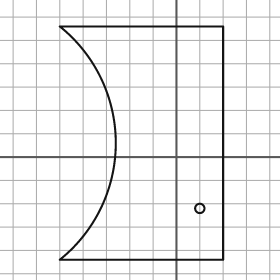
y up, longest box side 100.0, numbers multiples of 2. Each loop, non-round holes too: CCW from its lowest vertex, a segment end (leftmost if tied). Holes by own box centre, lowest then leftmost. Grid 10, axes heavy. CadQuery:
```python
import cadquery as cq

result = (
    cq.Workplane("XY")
    .moveTo(-50.0, -44.0)
    .lineTo(20.0, -44.0)
    .lineTo(20.0, 56.0)
    .lineTo(-50.0, 56.0)
    .threePointArc((-26.0, 6.0), (-50.0, -44.0))
    .close()
    .moveTo(10.0, -22.0)
    .circle(2.0)
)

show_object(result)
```